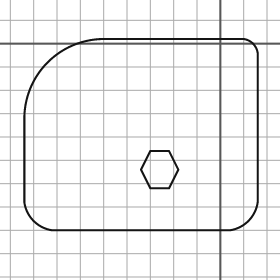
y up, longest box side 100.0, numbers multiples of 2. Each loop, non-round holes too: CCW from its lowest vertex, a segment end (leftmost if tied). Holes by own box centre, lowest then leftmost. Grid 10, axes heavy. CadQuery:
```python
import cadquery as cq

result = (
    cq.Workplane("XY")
    .moveTo(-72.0, -80.0)
    .lineTo(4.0, -80.0)
    .threePointArc((12.0, -76.0), (16.0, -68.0))
    .lineTo(16.0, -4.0)
    .threePointArc((14.0, 0.0), (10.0, 2.0))
    .lineTo(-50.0, 2.0)
    .threePointArc((-74.0, -8.0), (-84.0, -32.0))
    .lineTo(-84.0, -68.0)
    .threePointArc((-80.0, -76.0), (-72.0, -80.0))
    .close()
    .moveTo(-30.0, -62.0)
    .lineTo(-22.0, -62.0)
    .lineTo(-18.0, -54.0)
    .lineTo(-22.0, -46.0)
    .lineTo(-30.0, -46.0)
    .lineTo(-34.0, -54.0)
    .close()
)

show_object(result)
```